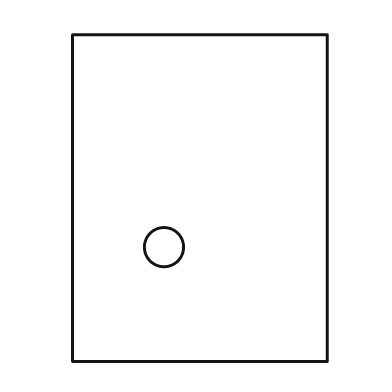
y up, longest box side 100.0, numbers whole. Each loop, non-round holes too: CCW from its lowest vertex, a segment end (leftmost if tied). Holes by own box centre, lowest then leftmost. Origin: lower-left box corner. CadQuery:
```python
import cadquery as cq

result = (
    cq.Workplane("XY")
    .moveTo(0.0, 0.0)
    .lineTo(78.0, 0.0)
    .lineTo(78.0, 100.0)
    .lineTo(0.0, 100.0)
    .close()
    .moveTo(28.0, 35.0)
    .circle(6.0)
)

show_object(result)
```